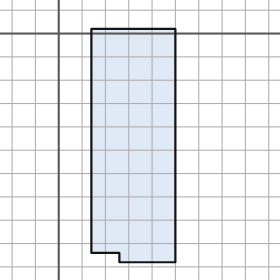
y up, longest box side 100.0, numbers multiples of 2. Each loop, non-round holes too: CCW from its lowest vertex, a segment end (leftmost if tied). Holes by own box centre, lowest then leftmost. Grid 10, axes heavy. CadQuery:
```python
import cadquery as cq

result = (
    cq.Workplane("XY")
    .moveTo(26.0, -98.0)
    .lineTo(50.0, -98.0)
    .lineTo(50.0, 2.0)
    .lineTo(14.0, 2.0)
    .lineTo(14.0, -94.0)
    .lineTo(26.0, -94.0)
    .close()
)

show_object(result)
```